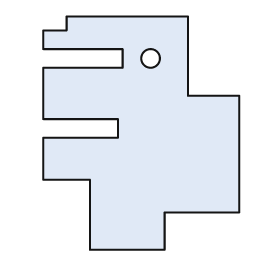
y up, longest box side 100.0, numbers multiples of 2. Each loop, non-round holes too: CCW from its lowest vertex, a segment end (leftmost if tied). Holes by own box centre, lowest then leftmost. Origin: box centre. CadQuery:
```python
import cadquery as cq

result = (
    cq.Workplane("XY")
    .moveTo(-22.0, -50.0)
    .lineTo(10.0, -50.0)
    .lineTo(10.0, -34.0)
    .lineTo(42.0, -34.0)
    .lineTo(42.0, 16.0)
    .lineTo(20.0, 16.0)
    .lineTo(20.0, 50.0)
    .lineTo(-32.0, 50.0)
    .lineTo(-32.0, 44.0)
    .lineTo(-42.0, 44.0)
    .lineTo(-42.0, 36.0)
    .lineTo(-8.0, 36.0)
    .lineTo(-8.0, 28.0)
    .lineTo(-42.0, 28.0)
    .lineTo(-42.0, 6.0)
    .lineTo(-10.0, 6.0)
    .lineTo(-10.0, -2.0)
    .lineTo(-42.0, -2.0)
    .lineTo(-42.0, -20.0)
    .lineTo(-22.0, -20.0)
    .close()
    .moveTo(4.0, 32.0)
    .circle(4.0)
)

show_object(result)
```